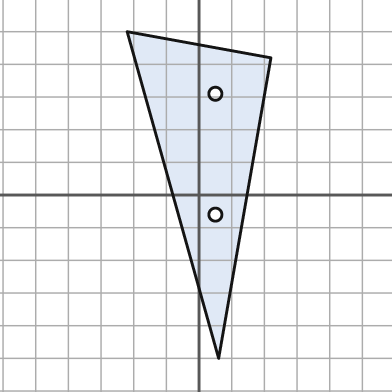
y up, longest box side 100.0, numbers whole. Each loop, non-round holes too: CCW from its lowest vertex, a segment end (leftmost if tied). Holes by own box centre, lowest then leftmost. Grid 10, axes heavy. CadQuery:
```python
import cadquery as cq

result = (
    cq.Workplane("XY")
    .moveTo(6.0, -50.0)
    .lineTo(22.0, 42.0)
    .lineTo(-22.0, 50.0)
    .close()
    .moveTo(5.0, -6.0)
    .circle(2.0)
    .moveTo(5.0, 31.0)
    .circle(2.0)
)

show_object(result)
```